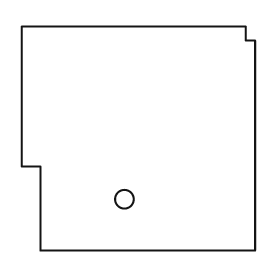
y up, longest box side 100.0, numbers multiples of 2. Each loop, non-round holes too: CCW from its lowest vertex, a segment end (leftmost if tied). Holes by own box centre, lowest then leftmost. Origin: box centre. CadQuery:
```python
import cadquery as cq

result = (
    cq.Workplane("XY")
    .moveTo(-42.0, -48.0)
    .lineTo(50.0, -48.0)
    .lineTo(50.0, 42.0)
    .lineTo(46.0, 42.0)
    .lineTo(46.0, 48.0)
    .lineTo(-50.0, 48.0)
    .lineTo(-50.0, -12.0)
    .lineTo(-42.0, -12.0)
    .close()
    .moveTo(-6.0, -26.0)
    .circle(4.0)
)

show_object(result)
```